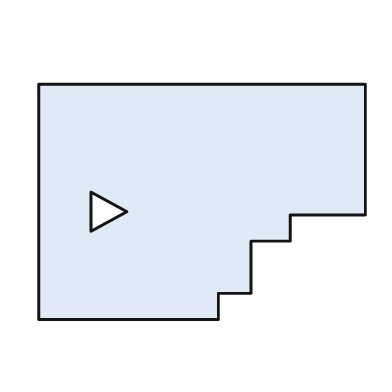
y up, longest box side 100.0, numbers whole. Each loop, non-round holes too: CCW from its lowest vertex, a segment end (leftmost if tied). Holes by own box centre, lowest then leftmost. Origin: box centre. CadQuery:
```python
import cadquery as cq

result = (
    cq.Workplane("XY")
    .moveTo(-50.0, -36.0)
    .lineTo(5.0, -36.0)
    .lineTo(5.0, -28.0)
    .lineTo(15.0, -28.0)
    .lineTo(15.0, -12.0)
    .lineTo(27.0, -12.0)
    .lineTo(27.0, -4.0)
    .lineTo(50.0, -4.0)
    .lineTo(50.0, 36.0)
    .lineTo(-50.0, 36.0)
    .close()
    .moveTo(-34.0, -9.0)
    .lineTo(-23.0, -3.0)
    .lineTo(-34.0, 3.0)
    .close()
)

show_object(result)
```